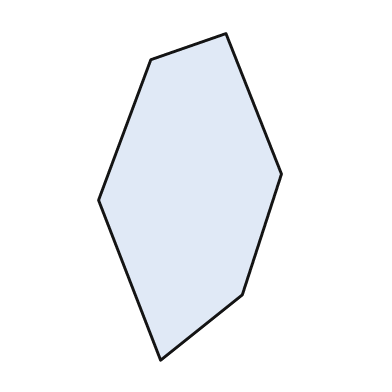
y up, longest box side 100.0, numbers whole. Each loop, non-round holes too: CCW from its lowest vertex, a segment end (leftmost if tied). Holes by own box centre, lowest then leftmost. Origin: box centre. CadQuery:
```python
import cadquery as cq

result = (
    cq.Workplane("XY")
    .moveTo(-9.0, -50.0)
    .lineTo(16.0, -30.0)
    .lineTo(28.0, 7.0)
    .lineTo(11.0, 50.0)
    .lineTo(-12.0, 42.0)
    .lineTo(-28.0, -1.0)
    .close()
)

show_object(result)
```